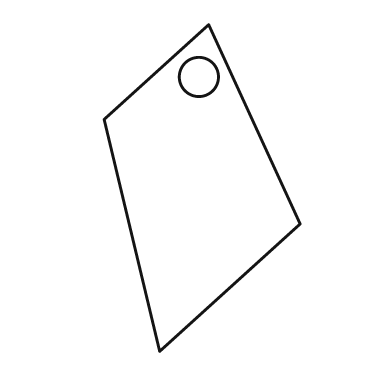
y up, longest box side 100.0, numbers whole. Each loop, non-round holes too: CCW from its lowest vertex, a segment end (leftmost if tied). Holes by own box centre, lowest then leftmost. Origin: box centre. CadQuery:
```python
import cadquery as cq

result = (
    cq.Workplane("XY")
    .moveTo(-13.0, -50.0)
    .lineTo(30.0, -11.0)
    .lineTo(2.0, 50.0)
    .lineTo(-30.0, 21.0)
    .close()
    .moveTo(-1.0, 34.0)
    .circle(6.0)
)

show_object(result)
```